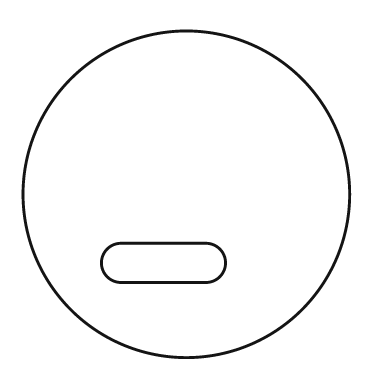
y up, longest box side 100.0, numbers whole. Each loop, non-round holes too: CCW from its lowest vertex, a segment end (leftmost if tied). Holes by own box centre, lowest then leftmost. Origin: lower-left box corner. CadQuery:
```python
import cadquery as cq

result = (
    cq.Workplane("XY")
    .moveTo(50.0, 50.0)
    .circle(50.0)
    .moveTo(30.0, 23.0)
    .lineTo(56.0, 23.0)
    .threePointArc((62.0, 29.0), (56.0, 35.0))
    .lineTo(30.0, 35.0)
    .threePointArc((24.0, 29.0), (30.0, 23.0))
    .close()
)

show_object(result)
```